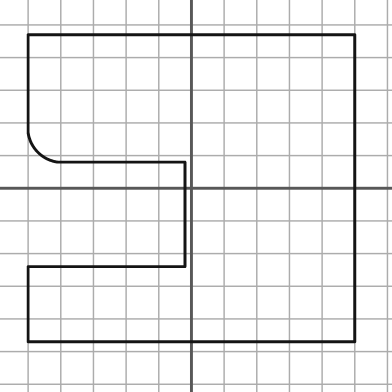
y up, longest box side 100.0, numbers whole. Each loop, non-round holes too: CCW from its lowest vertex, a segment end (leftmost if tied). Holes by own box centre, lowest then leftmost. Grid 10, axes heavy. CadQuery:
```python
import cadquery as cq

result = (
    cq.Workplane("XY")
    .moveTo(-50.0, -47.0)
    .lineTo(50.0, -47.0)
    .lineTo(50.0, 47.0)
    .lineTo(-50.0, 47.0)
    .lineTo(-50.0, 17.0)
    .threePointArc((-47.0, 11.0), (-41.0, 8.0))
    .lineTo(-2.0, 8.0)
    .lineTo(-2.0, -24.0)
    .lineTo(-50.0, -24.0)
    .close()
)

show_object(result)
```